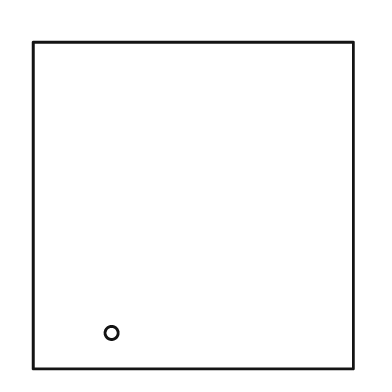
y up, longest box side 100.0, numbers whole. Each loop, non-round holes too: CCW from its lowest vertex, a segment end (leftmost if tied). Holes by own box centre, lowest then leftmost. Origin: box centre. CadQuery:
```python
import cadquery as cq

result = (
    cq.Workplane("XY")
    .moveTo(-49.0, -50.0)
    .lineTo(49.0, -50.0)
    .lineTo(49.0, 50.0)
    .lineTo(-49.0, 50.0)
    .close()
    .moveTo(-25.0, -39.0)
    .circle(2.0)
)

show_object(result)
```